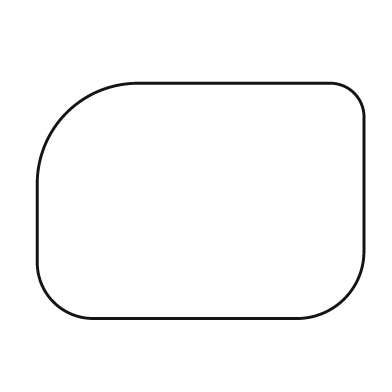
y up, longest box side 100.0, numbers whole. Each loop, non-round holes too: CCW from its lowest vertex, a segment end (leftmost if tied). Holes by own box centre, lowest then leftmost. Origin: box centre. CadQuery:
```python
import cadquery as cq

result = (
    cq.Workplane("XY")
    .moveTo(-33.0, -36.0)
    .lineTo(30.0, -36.0)
    .threePointArc((44.0, -30.0), (50.0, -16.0))
    .lineTo(50.0, 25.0)
    .threePointArc((47.0, 33.0), (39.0, 36.0))
    .lineTo(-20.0, 36.0)
    .threePointArc((-41.0, 27.0), (-50.0, 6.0))
    .lineTo(-50.0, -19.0)
    .threePointArc((-45.0, -31.0), (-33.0, -36.0))
    .close()
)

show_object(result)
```